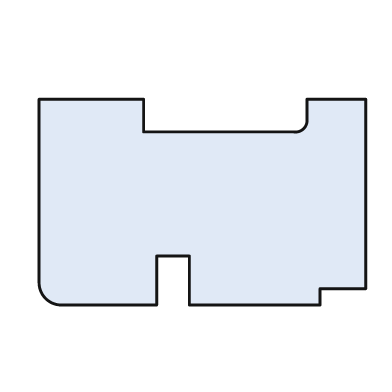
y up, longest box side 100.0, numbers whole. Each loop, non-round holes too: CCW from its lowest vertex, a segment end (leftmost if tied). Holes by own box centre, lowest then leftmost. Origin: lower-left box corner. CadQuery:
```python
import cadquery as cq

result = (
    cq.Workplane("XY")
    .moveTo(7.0, 0.0)
    .lineTo(36.0, 0.0)
    .lineTo(36.0, 15.0)
    .lineTo(46.0, 15.0)
    .lineTo(46.0, 0.0)
    .lineTo(86.0, 0.0)
    .lineTo(86.0, 5.0)
    .lineTo(100.0, 5.0)
    .lineTo(100.0, 63.0)
    .lineTo(82.0, 63.0)
    .lineTo(82.0, 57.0)
    .threePointArc((81.0, 54.0), (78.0, 53.0))
    .lineTo(32.0, 53.0)
    .lineTo(32.0, 63.0)
    .lineTo(0.0, 63.0)
    .lineTo(0.0, 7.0)
    .threePointArc((2.0, 2.0), (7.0, 0.0))
    .close()
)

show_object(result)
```